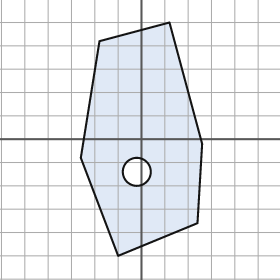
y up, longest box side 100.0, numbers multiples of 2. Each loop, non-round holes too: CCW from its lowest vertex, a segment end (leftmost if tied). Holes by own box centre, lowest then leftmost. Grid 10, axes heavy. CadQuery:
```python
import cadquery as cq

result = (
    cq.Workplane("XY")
    .moveTo(-10.0, -50.0)
    .lineTo(24.0, -36.0)
    .lineTo(26.0, -2.0)
    .lineTo(12.0, 50.0)
    .lineTo(-18.0, 42.0)
    .lineTo(-26.0, -8.0)
    .close()
    .moveTo(-2.0, -14.0)
    .circle(6.0)
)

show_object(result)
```